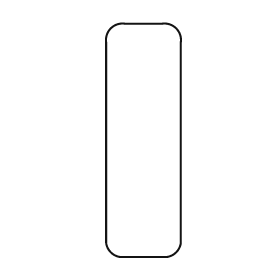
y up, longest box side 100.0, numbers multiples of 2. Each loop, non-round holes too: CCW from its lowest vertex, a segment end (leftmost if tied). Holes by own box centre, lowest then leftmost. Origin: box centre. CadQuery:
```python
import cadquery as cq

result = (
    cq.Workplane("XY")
    .moveTo(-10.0, -50.0)
    .lineTo(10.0, -50.0)
    .threePointArc((14.0, -48.0), (16.0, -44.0))
    .lineTo(16.0, 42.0)
    .threePointArc((14.0, 48.0), (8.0, 50.0))
    .lineTo(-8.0, 50.0)
    .threePointArc((-14.0, 48.0), (-16.0, 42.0))
    .lineTo(-16.0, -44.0)
    .threePointArc((-14.0, -48.0), (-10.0, -50.0))
    .close()
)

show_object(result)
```